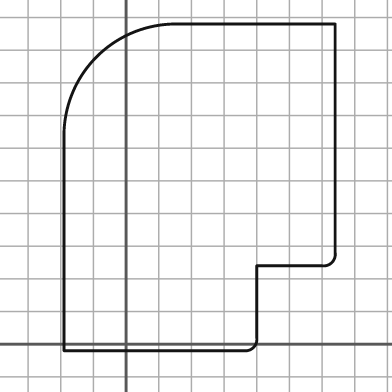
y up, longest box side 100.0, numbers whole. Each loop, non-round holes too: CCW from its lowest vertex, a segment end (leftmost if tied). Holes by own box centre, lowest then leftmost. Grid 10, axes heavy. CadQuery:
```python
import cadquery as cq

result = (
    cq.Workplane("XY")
    .moveTo(-19.0, -2.0)
    .lineTo(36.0, -2.0)
    .threePointArc((39.0, -1.0), (40.0, 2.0))
    .lineTo(40.0, 24.0)
    .lineTo(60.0, 24.0)
    .threePointArc((63.0, 25.0), (64.0, 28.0))
    .lineTo(64.0, 98.0)
    .lineTo(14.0, 98.0)
    .threePointArc((-9.0, 88.0), (-19.0, 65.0))
    .close()
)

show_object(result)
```